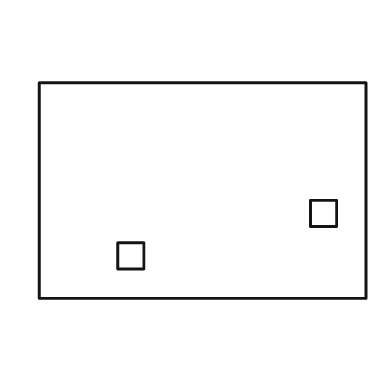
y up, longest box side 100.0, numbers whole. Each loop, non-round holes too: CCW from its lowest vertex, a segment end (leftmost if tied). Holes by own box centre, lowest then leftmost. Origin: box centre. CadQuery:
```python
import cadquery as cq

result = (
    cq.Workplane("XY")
    .moveTo(-50.0, -33.0)
    .lineTo(50.0, -33.0)
    .lineTo(50.0, 33.0)
    .lineTo(-50.0, 33.0)
    .close()
    .moveTo(-26.0, -24.0)
    .lineTo(-18.0, -24.0)
    .lineTo(-18.0, -16.0)
    .lineTo(-26.0, -16.0)
    .close()
    .moveTo(33.0, -11.0)
    .lineTo(41.0, -11.0)
    .lineTo(41.0, -3.0)
    .lineTo(33.0, -3.0)
    .close()
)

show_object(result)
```